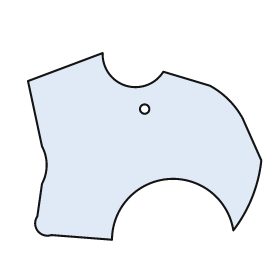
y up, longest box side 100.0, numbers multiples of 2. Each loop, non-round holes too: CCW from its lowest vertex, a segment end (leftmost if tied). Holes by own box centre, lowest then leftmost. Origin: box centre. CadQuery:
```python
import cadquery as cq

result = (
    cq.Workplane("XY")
    .moveTo(-14.0, -40.0)
    .threePointArc((10.0, -14.0), (38.0, -36.0))
    .threePointArc((46.0, -22.0), (50.0, -6.0))
    .lineTo(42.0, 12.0)
    .threePointArc((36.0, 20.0), (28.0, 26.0))
    .lineTo(8.0, 32.0)
    .threePointArc((-8.0, 26.0), (-18.0, 40.0))
    .lineTo(-50.0, 28.0)
    .lineTo(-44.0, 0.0)
    .threePointArc((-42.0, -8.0), (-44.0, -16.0))
    .lineTo(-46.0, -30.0)
    .threePointArc((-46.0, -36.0), (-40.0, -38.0))
    .close()
    .moveTo(0.0, 16.0)
    .circle(2.0)
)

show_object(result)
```